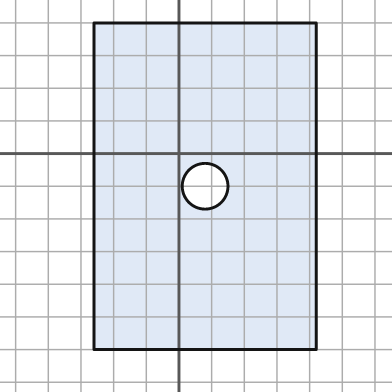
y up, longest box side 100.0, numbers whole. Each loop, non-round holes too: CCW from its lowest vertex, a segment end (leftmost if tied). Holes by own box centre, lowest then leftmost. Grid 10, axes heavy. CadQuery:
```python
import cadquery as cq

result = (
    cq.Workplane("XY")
    .moveTo(-26.0, -60.0)
    .lineTo(42.0, -60.0)
    .lineTo(42.0, 40.0)
    .lineTo(-26.0, 40.0)
    .close()
    .moveTo(8.0, -10.0)
    .circle(7.0)
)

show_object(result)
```